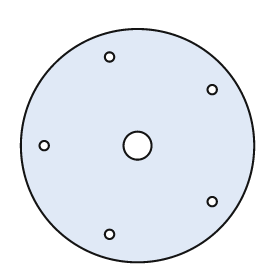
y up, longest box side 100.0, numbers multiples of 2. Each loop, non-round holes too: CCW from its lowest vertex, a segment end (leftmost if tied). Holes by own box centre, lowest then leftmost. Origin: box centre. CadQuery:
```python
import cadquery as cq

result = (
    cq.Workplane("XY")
    .moveTo(0.0, 0.0)
    .circle(50.0)
    .moveTo(-12.0, -38.0)
    .circle(2.0)
    .moveTo(32.0, -24.0)
    .circle(2.0)
    .moveTo(-40.0, 0.0)
    .circle(2.0)
    .moveTo(0.0, 0.0)
    .circle(6.0)
    .moveTo(32.0, 24.0)
    .circle(2.0)
    .moveTo(-12.0, 38.0)
    .circle(2.0)
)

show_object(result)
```